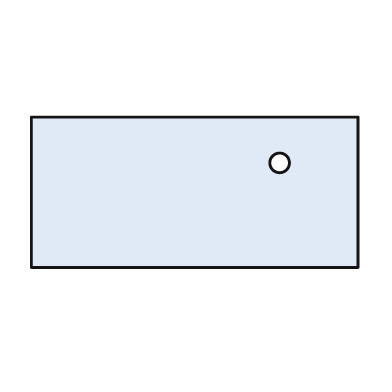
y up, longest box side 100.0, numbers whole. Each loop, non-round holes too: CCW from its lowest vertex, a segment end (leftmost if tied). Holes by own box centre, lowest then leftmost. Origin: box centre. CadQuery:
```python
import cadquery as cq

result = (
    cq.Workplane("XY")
    .moveTo(-50.0, -23.0)
    .lineTo(50.0, -23.0)
    .lineTo(50.0, 23.0)
    .lineTo(-50.0, 23.0)
    .close()
    .moveTo(26.0, 9.0)
    .circle(3.0)
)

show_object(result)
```